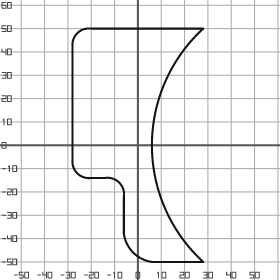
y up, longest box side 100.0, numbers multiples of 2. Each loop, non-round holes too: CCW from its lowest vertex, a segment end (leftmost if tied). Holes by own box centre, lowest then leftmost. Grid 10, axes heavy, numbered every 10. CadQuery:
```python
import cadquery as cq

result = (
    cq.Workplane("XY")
    .moveTo(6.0, -50.0)
    .lineTo(28.0, -50.0)
    .threePointArc((6.0, 0.0), (28.0, 50.0))
    .lineTo(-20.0, 50.0)
    .threePointArc((-26.0, 48.0), (-28.0, 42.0))
    .lineTo(-28.0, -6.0)
    .threePointArc((-26.0, -12.0), (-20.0, -14.0))
    .lineTo(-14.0, -14.0)
    .threePointArc((-8.0, -16.0), (-6.0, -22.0))
    .lineTo(-6.0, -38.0)
    .threePointArc((-2.0, -46.0), (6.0, -50.0))
    .close()
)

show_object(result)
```